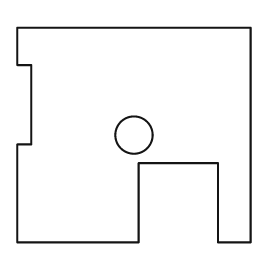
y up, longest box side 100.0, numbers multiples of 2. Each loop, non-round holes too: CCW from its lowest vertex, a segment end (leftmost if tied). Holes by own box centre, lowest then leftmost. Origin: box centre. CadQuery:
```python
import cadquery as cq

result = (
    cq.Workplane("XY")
    .moveTo(-50.0, -46.0)
    .lineTo(2.0, -46.0)
    .lineTo(2.0, -12.0)
    .lineTo(36.0, -12.0)
    .lineTo(36.0, -46.0)
    .lineTo(50.0, -46.0)
    .lineTo(50.0, 46.0)
    .lineTo(-50.0, 46.0)
    .lineTo(-50.0, 30.0)
    .lineTo(-44.0, 30.0)
    .lineTo(-44.0, -4.0)
    .lineTo(-50.0, -4.0)
    .close()
    .moveTo(0.0, 0.0)
    .circle(8.0)
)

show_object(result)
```